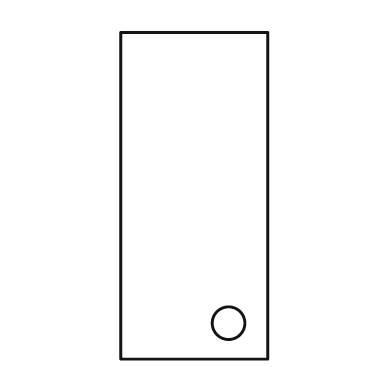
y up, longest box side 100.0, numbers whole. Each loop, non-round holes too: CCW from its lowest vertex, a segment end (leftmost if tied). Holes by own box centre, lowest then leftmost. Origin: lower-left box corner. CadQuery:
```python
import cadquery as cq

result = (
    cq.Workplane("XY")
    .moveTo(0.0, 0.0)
    .lineTo(45.0, 0.0)
    .lineTo(45.0, 100.0)
    .lineTo(0.0, 100.0)
    .close()
    .moveTo(33.0, 11.0)
    .circle(5.0)
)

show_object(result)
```